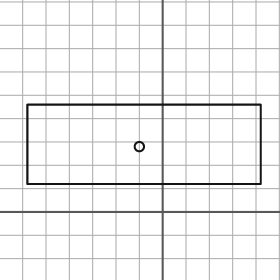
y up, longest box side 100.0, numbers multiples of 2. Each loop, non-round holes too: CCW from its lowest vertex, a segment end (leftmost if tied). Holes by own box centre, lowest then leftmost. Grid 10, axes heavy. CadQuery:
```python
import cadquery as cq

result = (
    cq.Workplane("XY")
    .moveTo(-58.0, 12.0)
    .lineTo(42.0, 12.0)
    .lineTo(42.0, 46.0)
    .lineTo(-58.0, 46.0)
    .close()
    .moveTo(-10.0, 28.0)
    .circle(2.0)
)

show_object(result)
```